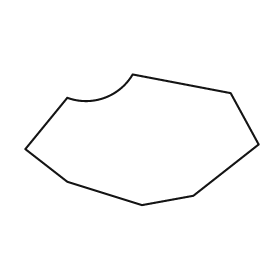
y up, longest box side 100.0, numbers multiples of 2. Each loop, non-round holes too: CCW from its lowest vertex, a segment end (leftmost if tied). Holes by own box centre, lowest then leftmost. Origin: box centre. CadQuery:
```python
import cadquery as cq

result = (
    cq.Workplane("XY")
    .moveTo(0.0, -28.0)
    .lineTo(22.0, -24.0)
    .lineTo(50.0, -2.0)
    .lineTo(38.0, 20.0)
    .lineTo(-4.0, 28.0)
    .threePointArc((-16.0, 18.0), (-32.0, 18.0))
    .lineTo(-50.0, -4.0)
    .lineTo(-32.0, -18.0)
    .close()
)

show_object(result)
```